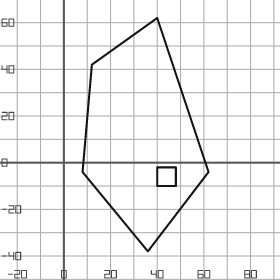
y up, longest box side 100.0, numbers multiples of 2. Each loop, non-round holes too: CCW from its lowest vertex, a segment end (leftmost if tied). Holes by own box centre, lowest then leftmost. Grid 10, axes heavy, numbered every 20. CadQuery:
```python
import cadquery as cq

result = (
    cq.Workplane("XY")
    .moveTo(36.0, -38.0)
    .lineTo(62.0, -4.0)
    .lineTo(40.0, 62.0)
    .lineTo(12.0, 42.0)
    .lineTo(8.0, -4.0)
    .close()
    .moveTo(40.0, -10.0)
    .lineTo(48.0, -10.0)
    .lineTo(48.0, -2.0)
    .lineTo(40.0, -2.0)
    .close()
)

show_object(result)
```